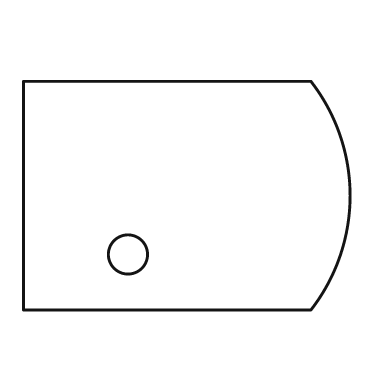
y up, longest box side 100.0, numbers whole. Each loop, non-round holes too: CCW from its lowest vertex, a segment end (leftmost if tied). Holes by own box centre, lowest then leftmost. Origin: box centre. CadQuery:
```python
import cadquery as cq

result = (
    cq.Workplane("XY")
    .moveTo(-50.0, -35.0)
    .lineTo(38.0, -35.0)
    .threePointArc((50.0, 0.0), (38.0, 35.0))
    .lineTo(-50.0, 35.0)
    .close()
    .moveTo(-18.0, -18.0)
    .circle(6.0)
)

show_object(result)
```